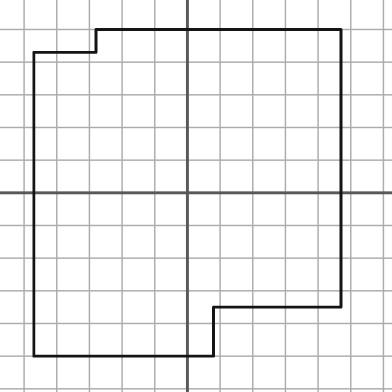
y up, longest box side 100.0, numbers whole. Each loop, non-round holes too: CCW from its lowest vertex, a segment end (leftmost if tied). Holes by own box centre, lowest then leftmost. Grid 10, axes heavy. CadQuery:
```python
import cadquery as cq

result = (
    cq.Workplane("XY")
    .moveTo(-47.0, -50.0)
    .lineTo(8.0, -50.0)
    .lineTo(8.0, -35.0)
    .lineTo(47.0, -35.0)
    .lineTo(47.0, 50.0)
    .lineTo(-28.0, 50.0)
    .lineTo(-28.0, 43.0)
    .lineTo(-47.0, 43.0)
    .close()
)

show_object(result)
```